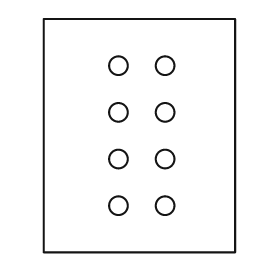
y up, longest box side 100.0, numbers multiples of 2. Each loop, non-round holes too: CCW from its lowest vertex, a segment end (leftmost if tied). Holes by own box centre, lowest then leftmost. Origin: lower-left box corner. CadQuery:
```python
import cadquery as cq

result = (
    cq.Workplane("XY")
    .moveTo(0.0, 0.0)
    .lineTo(82.0, 0.0)
    .lineTo(82.0, 100.0)
    .lineTo(0.0, 100.0)
    .close()
    .moveTo(32.0, 20.0)
    .circle(4.0)
    .moveTo(52.0, 20.0)
    .circle(4.0)
    .moveTo(32.0, 40.0)
    .circle(4.0)
    .moveTo(52.0, 40.0)
    .circle(4.0)
    .moveTo(32.0, 60.0)
    .circle(4.0)
    .moveTo(52.0, 60.0)
    .circle(4.0)
    .moveTo(32.0, 80.0)
    .circle(4.0)
    .moveTo(52.0, 80.0)
    .circle(4.0)
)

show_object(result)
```